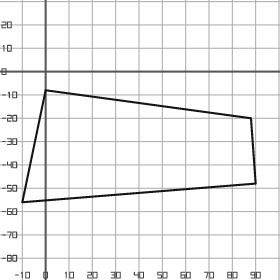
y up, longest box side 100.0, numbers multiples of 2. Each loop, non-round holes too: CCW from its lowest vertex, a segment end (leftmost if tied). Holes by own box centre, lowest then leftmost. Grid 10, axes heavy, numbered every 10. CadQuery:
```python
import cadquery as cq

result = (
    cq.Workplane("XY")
    .moveTo(-10.0, -56.0)
    .lineTo(90.0, -48.0)
    .lineTo(88.0, -20.0)
    .lineTo(0.0, -8.0)
    .close()
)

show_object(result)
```